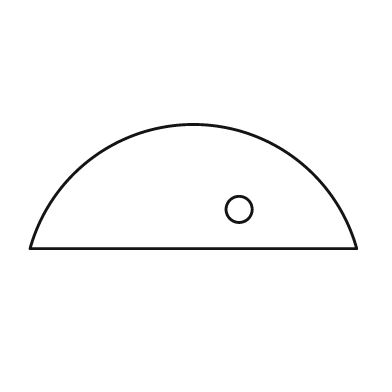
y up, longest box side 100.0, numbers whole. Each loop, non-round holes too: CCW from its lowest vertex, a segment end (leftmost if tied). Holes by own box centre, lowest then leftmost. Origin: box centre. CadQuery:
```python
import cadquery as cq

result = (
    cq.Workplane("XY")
    .moveTo(-50.0, -19.0)
    .lineTo(50.0, -19.0)
    .threePointArc((0.0, 19.0), (-50.0, -19.0))
    .close()
    .moveTo(14.0, -7.0)
    .circle(4.0)
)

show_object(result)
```